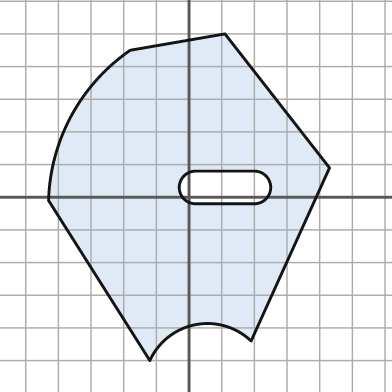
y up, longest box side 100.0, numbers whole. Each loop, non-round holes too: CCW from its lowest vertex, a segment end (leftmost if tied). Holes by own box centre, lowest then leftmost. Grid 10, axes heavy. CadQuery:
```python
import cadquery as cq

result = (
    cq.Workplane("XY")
    .moveTo(-12.0, -50.0)
    .threePointArc((2.0, -39.0), (19.0, -44.0))
    .lineTo(43.0, 9.0)
    .lineTo(11.0, 50.0)
    .lineTo(-18.0, 45.0)
    .threePointArc((-36.0, 25.0), (-43.0, -1.0))
    .close()
    .moveTo(2.0, -2.0)
    .lineTo(20.0, -2.0)
    .threePointArc((25.0, 3.0), (20.0, 8.0))
    .lineTo(2.0, 8.0)
    .threePointArc((-3.0, 3.0), (2.0, -2.0))
    .close()
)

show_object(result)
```